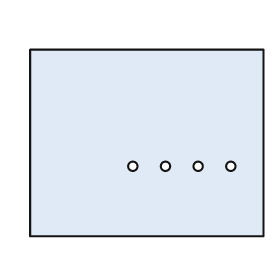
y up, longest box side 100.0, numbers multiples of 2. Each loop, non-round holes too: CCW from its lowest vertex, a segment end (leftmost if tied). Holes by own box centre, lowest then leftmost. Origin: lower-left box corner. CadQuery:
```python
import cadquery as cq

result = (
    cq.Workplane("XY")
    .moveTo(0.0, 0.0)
    .lineTo(100.0, 0.0)
    .lineTo(100.0, 80.0)
    .lineTo(0.0, 80.0)
    .close()
    .moveTo(44.0, 30.0)
    .circle(2.0)
    .moveTo(58.0, 30.0)
    .circle(2.0)
    .moveTo(72.0, 30.0)
    .circle(2.0)
    .moveTo(86.0, 30.0)
    .circle(2.0)
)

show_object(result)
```